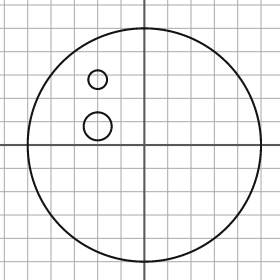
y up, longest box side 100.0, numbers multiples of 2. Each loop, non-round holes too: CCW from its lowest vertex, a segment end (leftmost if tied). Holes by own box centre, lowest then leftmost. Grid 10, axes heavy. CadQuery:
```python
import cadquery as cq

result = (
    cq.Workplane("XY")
    .moveTo(0.0, 0.0)
    .circle(50.0)
    .moveTo(-20.0, 8.0)
    .circle(6.0)
    .moveTo(-20.0, 28.0)
    .circle(4.0)
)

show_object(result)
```